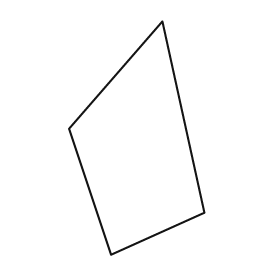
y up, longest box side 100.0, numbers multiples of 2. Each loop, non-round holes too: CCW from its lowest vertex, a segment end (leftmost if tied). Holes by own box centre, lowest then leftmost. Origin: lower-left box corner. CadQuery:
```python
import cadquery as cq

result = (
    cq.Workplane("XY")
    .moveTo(18.0, 0.0)
    .lineTo(58.0, 18.0)
    .lineTo(40.0, 100.0)
    .lineTo(0.0, 54.0)
    .close()
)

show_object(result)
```